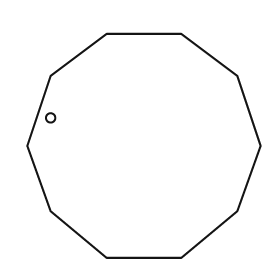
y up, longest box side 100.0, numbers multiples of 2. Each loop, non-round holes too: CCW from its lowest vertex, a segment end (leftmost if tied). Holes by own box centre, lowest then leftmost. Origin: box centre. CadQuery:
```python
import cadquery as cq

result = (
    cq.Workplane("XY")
    .moveTo(-16.0, -48.0)
    .lineTo(16.0, -48.0)
    .lineTo(40.0, -28.0)
    .lineTo(50.0, 0.0)
    .lineTo(40.0, 30.0)
    .lineTo(16.0, 48.0)
    .lineTo(-16.0, 48.0)
    .lineTo(-40.0, 30.0)
    .lineTo(-50.0, 0.0)
    .lineTo(-40.0, -28.0)
    .close()
    .moveTo(-40.0, 12.0)
    .circle(2.0)
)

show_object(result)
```